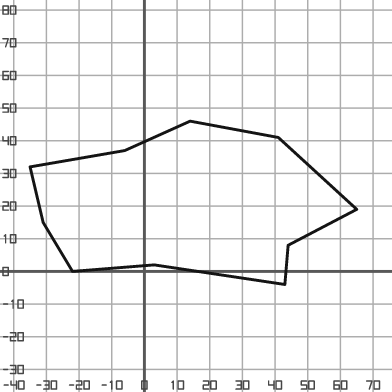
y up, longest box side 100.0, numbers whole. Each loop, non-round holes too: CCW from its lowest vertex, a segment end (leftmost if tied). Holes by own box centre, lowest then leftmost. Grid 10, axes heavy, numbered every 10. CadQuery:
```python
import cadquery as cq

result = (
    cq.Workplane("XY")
    .moveTo(43.0, -4.0)
    .lineTo(44.0, 8.0)
    .lineTo(65.0, 19.0)
    .lineTo(41.0, 41.0)
    .lineTo(14.0, 46.0)
    .lineTo(-6.0, 37.0)
    .lineTo(-35.0, 32.0)
    .lineTo(-31.0, 15.0)
    .lineTo(-22.0, 0.0)
    .lineTo(3.0, 2.0)
    .close()
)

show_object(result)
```